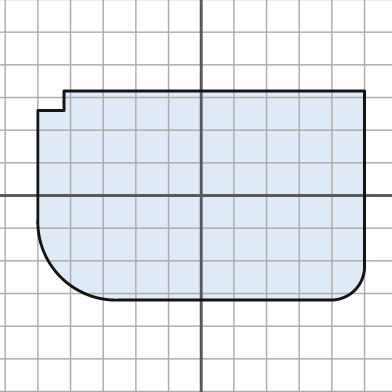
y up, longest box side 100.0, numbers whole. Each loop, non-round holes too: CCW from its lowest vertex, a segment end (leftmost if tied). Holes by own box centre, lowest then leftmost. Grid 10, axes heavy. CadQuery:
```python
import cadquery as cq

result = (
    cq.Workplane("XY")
    .moveTo(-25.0, -32.0)
    .lineTo(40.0, -32.0)
    .threePointArc((47.0, -29.0), (50.0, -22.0))
    .lineTo(50.0, 32.0)
    .lineTo(-42.0, 32.0)
    .lineTo(-42.0, 26.0)
    .lineTo(-50.0, 26.0)
    .lineTo(-50.0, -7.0)
    .threePointArc((-43.0, -25.0), (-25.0, -32.0))
    .close()
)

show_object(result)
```